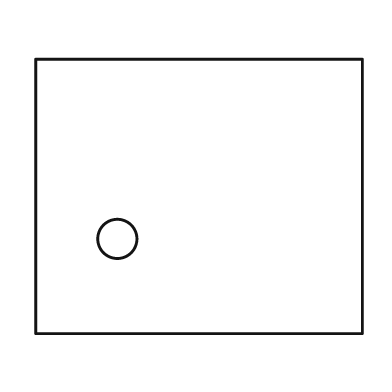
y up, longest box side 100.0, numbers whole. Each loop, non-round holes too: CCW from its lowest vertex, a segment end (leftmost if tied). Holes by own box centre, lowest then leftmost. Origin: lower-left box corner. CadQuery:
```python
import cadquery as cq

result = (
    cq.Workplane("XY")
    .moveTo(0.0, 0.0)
    .lineTo(100.0, 0.0)
    .lineTo(100.0, 84.0)
    .lineTo(0.0, 84.0)
    .close()
    .moveTo(25.0, 29.0)
    .circle(6.0)
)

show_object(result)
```